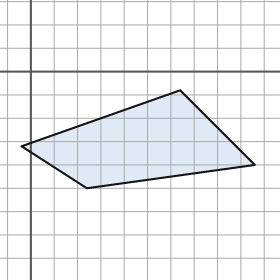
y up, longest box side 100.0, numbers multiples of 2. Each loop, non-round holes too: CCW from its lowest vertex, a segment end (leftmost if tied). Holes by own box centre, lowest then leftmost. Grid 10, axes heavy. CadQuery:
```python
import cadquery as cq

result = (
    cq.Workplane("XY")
    .moveTo(24.0, -50.0)
    .lineTo(96.0, -40.0)
    .lineTo(64.0, -8.0)
    .lineTo(-4.0, -32.0)
    .close()
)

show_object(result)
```